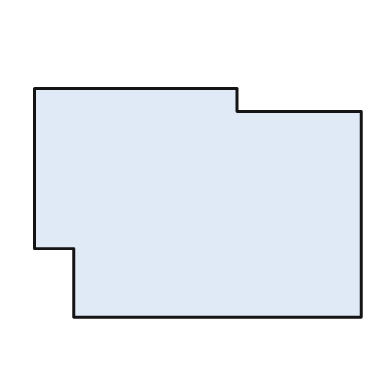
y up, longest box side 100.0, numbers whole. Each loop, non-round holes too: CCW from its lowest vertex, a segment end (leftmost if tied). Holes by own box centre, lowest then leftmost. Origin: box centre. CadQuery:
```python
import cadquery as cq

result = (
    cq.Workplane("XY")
    .moveTo(-38.0, -35.0)
    .lineTo(50.0, -35.0)
    .lineTo(50.0, 28.0)
    .lineTo(12.0, 28.0)
    .lineTo(12.0, 35.0)
    .lineTo(-50.0, 35.0)
    .lineTo(-50.0, -14.0)
    .lineTo(-38.0, -14.0)
    .close()
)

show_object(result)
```